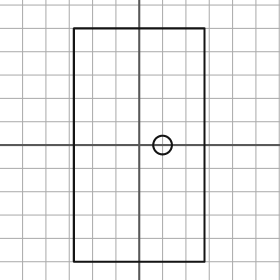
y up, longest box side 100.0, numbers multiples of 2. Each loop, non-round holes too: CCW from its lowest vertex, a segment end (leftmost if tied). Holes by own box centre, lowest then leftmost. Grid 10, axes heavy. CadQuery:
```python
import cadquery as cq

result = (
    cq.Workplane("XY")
    .moveTo(-28.0, -50.0)
    .lineTo(28.0, -50.0)
    .lineTo(28.0, 50.0)
    .lineTo(-28.0, 50.0)
    .close()
    .moveTo(10.0, 0.0)
    .circle(4.0)
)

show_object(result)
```